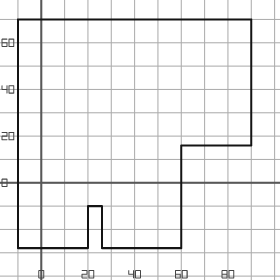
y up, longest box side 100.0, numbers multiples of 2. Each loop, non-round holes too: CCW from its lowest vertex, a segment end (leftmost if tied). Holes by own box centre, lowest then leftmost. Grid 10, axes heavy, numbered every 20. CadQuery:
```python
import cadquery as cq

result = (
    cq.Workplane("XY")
    .moveTo(-10.0, -28.0)
    .lineTo(20.0, -28.0)
    .lineTo(20.0, -10.0)
    .lineTo(26.0, -10.0)
    .lineTo(26.0, -28.0)
    .lineTo(60.0, -28.0)
    .lineTo(60.0, 16.0)
    .lineTo(90.0, 16.0)
    .lineTo(90.0, 70.0)
    .lineTo(-10.0, 70.0)
    .close()
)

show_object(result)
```